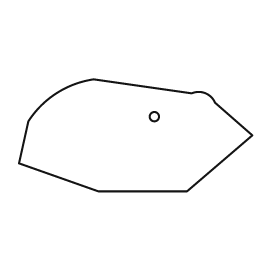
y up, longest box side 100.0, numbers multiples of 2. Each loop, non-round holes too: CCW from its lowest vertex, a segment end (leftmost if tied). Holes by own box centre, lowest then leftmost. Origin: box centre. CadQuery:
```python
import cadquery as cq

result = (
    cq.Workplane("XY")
    .moveTo(-16.0, -24.0)
    .lineTo(22.0, -24.0)
    .lineTo(50.0, 0.0)
    .lineTo(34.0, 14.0)
    .threePointArc((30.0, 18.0), (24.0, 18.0))
    .lineTo(-18.0, 24.0)
    .threePointArc((-34.0, 18.0), (-46.0, 6.0))
    .lineTo(-50.0, -12.0)
    .close()
    .moveTo(8.0, 8.0)
    .circle(2.0)
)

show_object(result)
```